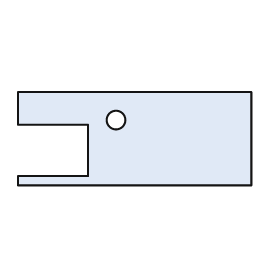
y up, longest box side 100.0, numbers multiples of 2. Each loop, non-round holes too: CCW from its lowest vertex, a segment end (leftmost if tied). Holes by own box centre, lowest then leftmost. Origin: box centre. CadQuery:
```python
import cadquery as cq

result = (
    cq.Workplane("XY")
    .moveTo(-50.0, -20.0)
    .lineTo(50.0, -20.0)
    .lineTo(50.0, 20.0)
    .lineTo(-50.0, 20.0)
    .lineTo(-50.0, 6.0)
    .lineTo(-20.0, 6.0)
    .lineTo(-20.0, -16.0)
    .lineTo(-50.0, -16.0)
    .close()
    .moveTo(-8.0, 8.0)
    .circle(4.0)
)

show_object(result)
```